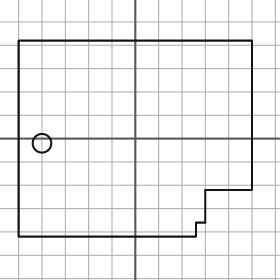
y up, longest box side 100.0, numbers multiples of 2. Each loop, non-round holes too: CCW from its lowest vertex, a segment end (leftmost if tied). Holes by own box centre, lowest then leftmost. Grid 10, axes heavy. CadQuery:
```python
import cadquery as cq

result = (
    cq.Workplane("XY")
    .moveTo(-50.0, -42.0)
    .lineTo(26.0, -42.0)
    .lineTo(26.0, -36.0)
    .lineTo(30.0, -36.0)
    .lineTo(30.0, -22.0)
    .lineTo(50.0, -22.0)
    .lineTo(50.0, 42.0)
    .lineTo(-50.0, 42.0)
    .close()
    .moveTo(-40.0, -2.0)
    .circle(4.0)
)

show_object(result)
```